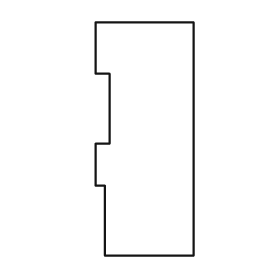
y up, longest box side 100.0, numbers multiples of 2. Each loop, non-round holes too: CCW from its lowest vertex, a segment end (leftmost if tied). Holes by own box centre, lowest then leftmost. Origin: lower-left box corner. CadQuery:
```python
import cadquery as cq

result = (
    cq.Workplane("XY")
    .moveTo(4.0, 0.0)
    .lineTo(42.0, 0.0)
    .lineTo(42.0, 100.0)
    .lineTo(0.0, 100.0)
    .lineTo(0.0, 78.0)
    .lineTo(6.0, 78.0)
    .lineTo(6.0, 48.0)
    .lineTo(0.0, 48.0)
    .lineTo(0.0, 30.0)
    .lineTo(4.0, 30.0)
    .close()
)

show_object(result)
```